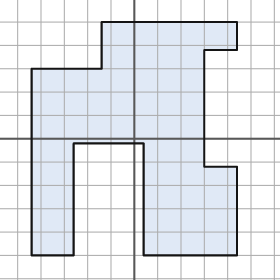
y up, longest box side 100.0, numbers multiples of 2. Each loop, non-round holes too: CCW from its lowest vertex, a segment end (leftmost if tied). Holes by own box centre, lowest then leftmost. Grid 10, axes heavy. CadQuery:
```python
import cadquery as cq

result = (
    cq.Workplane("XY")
    .moveTo(-44.0, -50.0)
    .lineTo(-26.0, -50.0)
    .lineTo(-26.0, -2.0)
    .lineTo(4.0, -2.0)
    .lineTo(4.0, -50.0)
    .lineTo(44.0, -50.0)
    .lineTo(44.0, -12.0)
    .lineTo(30.0, -12.0)
    .lineTo(30.0, 38.0)
    .lineTo(44.0, 38.0)
    .lineTo(44.0, 50.0)
    .lineTo(-14.0, 50.0)
    .lineTo(-14.0, 30.0)
    .lineTo(-44.0, 30.0)
    .close()
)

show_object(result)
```